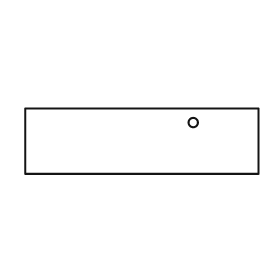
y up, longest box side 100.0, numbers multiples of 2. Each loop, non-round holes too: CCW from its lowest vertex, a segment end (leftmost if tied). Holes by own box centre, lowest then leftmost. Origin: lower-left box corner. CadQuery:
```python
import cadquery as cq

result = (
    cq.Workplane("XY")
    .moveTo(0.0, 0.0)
    .lineTo(100.0, 0.0)
    .lineTo(100.0, 28.0)
    .lineTo(0.0, 28.0)
    .close()
    .moveTo(72.0, 22.0)
    .circle(2.0)
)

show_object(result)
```